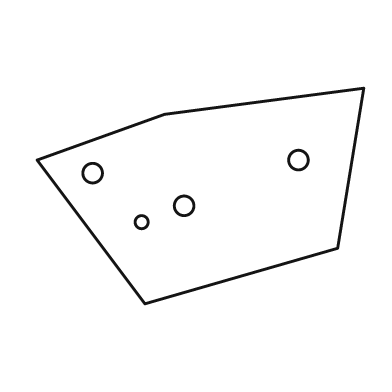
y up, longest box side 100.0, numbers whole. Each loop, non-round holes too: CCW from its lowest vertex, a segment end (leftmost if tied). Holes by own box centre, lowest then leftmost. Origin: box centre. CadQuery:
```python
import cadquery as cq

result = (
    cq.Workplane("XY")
    .moveTo(-17.0, -33.0)
    .lineTo(42.0, -16.0)
    .lineTo(50.0, 33.0)
    .lineTo(-11.0, 25.0)
    .lineTo(-50.0, 11.0)
    .close()
    .moveTo(-18.0, -8.0)
    .circle(2.0)
    .moveTo(-5.0, -3.0)
    .circle(3.0)
    .moveTo(-33.0, 7.0)
    .circle(3.0)
    .moveTo(30.0, 11.0)
    .circle(3.0)
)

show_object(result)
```